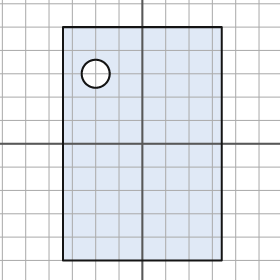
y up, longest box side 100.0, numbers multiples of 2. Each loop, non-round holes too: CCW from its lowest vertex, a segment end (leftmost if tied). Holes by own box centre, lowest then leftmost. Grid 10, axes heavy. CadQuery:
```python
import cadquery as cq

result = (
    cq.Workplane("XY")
    .moveTo(-34.0, -50.0)
    .lineTo(34.0, -50.0)
    .lineTo(34.0, 50.0)
    .lineTo(-34.0, 50.0)
    .close()
    .moveTo(-20.0, 30.0)
    .circle(6.0)
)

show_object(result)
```